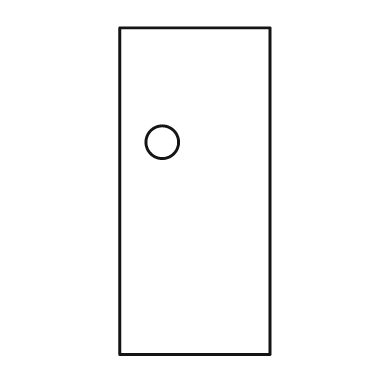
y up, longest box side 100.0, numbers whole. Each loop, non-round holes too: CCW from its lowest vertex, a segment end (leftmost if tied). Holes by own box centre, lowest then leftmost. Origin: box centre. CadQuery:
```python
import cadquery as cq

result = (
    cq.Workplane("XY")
    .moveTo(-23.0, -50.0)
    .lineTo(23.0, -50.0)
    .lineTo(23.0, 50.0)
    .lineTo(-23.0, 50.0)
    .close()
    .moveTo(-10.0, 15.0)
    .circle(5.0)
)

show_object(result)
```